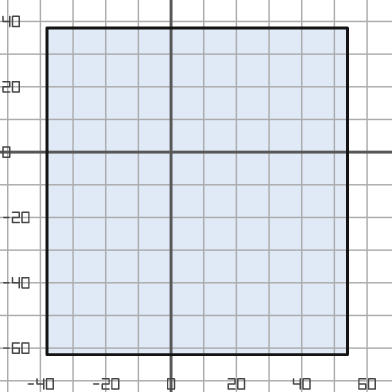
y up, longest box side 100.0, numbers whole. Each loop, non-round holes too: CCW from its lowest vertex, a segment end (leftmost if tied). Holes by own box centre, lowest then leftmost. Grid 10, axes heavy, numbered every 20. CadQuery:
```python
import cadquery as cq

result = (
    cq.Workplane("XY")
    .moveTo(-38.0, -62.0)
    .lineTo(54.0, -62.0)
    .lineTo(54.0, 38.0)
    .lineTo(-38.0, 38.0)
    .close()
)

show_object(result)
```